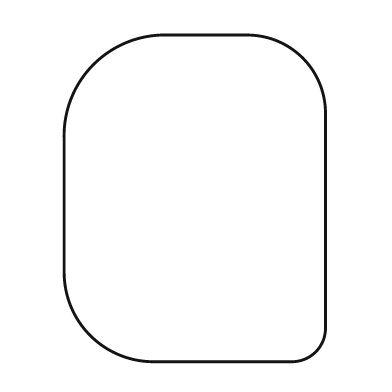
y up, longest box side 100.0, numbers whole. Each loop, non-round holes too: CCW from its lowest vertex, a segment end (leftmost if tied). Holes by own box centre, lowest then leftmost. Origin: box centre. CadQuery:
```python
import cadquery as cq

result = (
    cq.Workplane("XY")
    .moveTo(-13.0, -50.0)
    .lineTo(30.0, -50.0)
    .threePointArc((37.0, -47.0), (40.0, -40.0))
    .lineTo(40.0, 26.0)
    .threePointArc((33.0, 43.0), (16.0, 50.0))
    .lineTo(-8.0, 50.0)
    .threePointArc((-31.0, 41.0), (-40.0, 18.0))
    .lineTo(-40.0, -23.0)
    .threePointArc((-32.0, -42.0), (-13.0, -50.0))
    .close()
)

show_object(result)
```